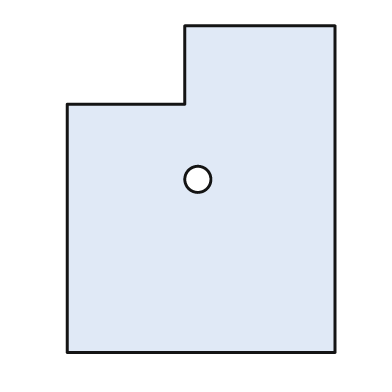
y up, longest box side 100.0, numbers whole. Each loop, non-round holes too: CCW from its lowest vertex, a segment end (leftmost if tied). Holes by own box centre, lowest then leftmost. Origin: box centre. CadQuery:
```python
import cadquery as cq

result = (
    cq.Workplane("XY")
    .moveTo(-41.0, -50.0)
    .lineTo(41.0, -50.0)
    .lineTo(41.0, 50.0)
    .lineTo(-5.0, 50.0)
    .lineTo(-5.0, 26.0)
    .lineTo(-41.0, 26.0)
    .close()
    .moveTo(-1.0, 3.0)
    .circle(4.0)
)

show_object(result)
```